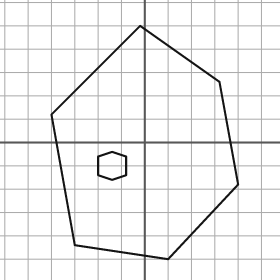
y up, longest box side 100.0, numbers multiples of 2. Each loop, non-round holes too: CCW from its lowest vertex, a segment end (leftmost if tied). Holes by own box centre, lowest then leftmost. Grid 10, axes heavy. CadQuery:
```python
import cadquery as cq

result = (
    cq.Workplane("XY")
    .moveTo(10.0, -50.0)
    .lineTo(40.0, -18.0)
    .lineTo(32.0, 26.0)
    .lineTo(-2.0, 50.0)
    .lineTo(-40.0, 12.0)
    .lineTo(-30.0, -44.0)
    .close()
    .moveTo(-14.0, -16.0)
    .lineTo(-8.0, -14.0)
    .lineTo(-8.0, -6.0)
    .lineTo(-14.0, -4.0)
    .lineTo(-20.0, -6.0)
    .lineTo(-20.0, -14.0)
    .close()
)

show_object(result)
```